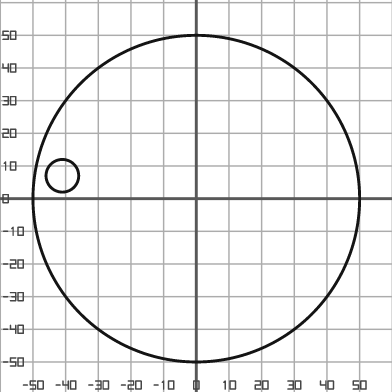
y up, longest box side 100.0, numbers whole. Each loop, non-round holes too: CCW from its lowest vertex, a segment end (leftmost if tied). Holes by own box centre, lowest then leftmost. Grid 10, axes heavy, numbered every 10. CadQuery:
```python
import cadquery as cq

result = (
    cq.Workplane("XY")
    .moveTo(0.0, 0.0)
    .circle(50.0)
    .moveTo(-41.0, 7.0)
    .circle(5.0)
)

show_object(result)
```